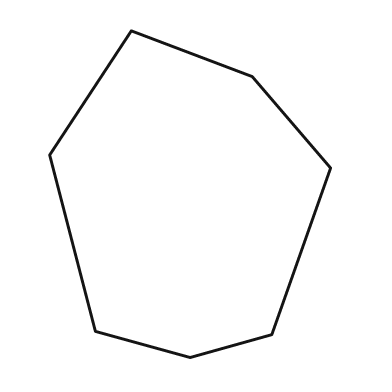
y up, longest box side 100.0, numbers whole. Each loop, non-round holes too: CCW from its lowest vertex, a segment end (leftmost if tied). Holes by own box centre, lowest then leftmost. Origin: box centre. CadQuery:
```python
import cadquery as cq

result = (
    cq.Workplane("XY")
    .moveTo(0.0, -50.0)
    .lineTo(25.0, -43.0)
    .lineTo(43.0, 8.0)
    .lineTo(19.0, 36.0)
    .lineTo(-18.0, 50.0)
    .lineTo(-43.0, 12.0)
    .lineTo(-29.0, -42.0)
    .close()
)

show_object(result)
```